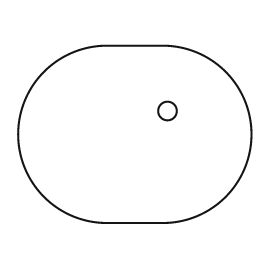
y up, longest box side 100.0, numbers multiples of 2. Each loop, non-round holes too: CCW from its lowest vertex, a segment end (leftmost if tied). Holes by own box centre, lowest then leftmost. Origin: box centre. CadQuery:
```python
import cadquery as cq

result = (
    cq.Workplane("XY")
    .moveTo(-12.0, -38.0)
    .lineTo(12.0, -38.0)
    .threePointArc((50.0, 0.0), (12.0, 38.0))
    .lineTo(-12.0, 38.0)
    .threePointArc((-50.0, 0.0), (-12.0, -38.0))
    .close()
    .moveTo(14.0, 10.0)
    .circle(4.0)
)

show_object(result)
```